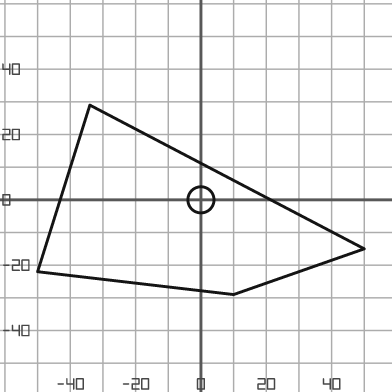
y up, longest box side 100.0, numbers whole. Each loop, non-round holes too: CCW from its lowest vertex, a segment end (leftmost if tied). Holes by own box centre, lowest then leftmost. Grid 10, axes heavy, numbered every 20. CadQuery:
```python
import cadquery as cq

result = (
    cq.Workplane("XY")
    .moveTo(10.0, -29.0)
    .lineTo(50.0, -15.0)
    .lineTo(-34.0, 29.0)
    .lineTo(-50.0, -22.0)
    .close()
    .moveTo(0.0, 0.0)
    .circle(4.0)
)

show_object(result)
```